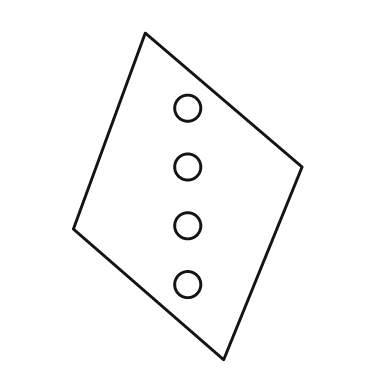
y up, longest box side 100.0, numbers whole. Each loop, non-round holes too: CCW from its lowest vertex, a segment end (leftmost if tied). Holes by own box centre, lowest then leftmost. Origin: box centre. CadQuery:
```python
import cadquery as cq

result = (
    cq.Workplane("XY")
    .moveTo(11.0, -50.0)
    .lineTo(35.0, 9.0)
    .lineTo(-13.0, 50.0)
    .lineTo(-35.0, -10.0)
    .close()
    .moveTo(0.0, -27.0)
    .circle(4.0)
    .moveTo(0.0, -9.0)
    .circle(4.0)
    .moveTo(0.0, 9.0)
    .circle(4.0)
    .moveTo(0.0, 27.0)
    .circle(4.0)
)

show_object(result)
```